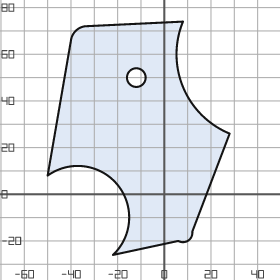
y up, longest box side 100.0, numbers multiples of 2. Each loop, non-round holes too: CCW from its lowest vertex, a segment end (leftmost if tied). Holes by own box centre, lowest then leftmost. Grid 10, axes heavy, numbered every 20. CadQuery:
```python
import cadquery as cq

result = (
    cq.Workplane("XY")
    .moveTo(-22.0, -26.0)
    .lineTo(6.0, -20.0)
    .threePointArc((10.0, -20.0), (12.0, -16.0))
    .lineTo(28.0, 26.0)
    .threePointArc((8.0, 46.0), (8.0, 74.0))
    .lineTo(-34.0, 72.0)
    .threePointArc((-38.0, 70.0), (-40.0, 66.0))
    .lineTo(-50.0, 8.0)
    .threePointArc((-20.0, 4.0), (-22.0, -26.0))
    .close()
    .moveTo(-12.0, 50.0)
    .circle(4.0)
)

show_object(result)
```